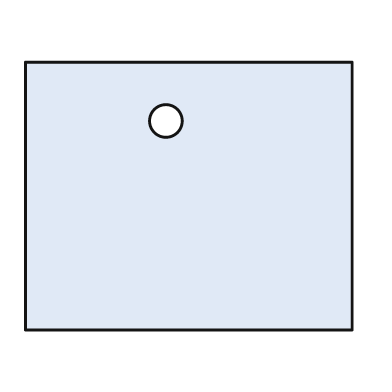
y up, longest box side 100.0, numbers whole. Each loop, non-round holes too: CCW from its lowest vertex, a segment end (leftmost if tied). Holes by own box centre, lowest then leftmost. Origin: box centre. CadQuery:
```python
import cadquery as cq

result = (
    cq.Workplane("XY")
    .moveTo(-50.0, -41.0)
    .lineTo(50.0, -41.0)
    .lineTo(50.0, 41.0)
    .lineTo(-50.0, 41.0)
    .close()
    .moveTo(-7.0, 23.0)
    .circle(5.0)
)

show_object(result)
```